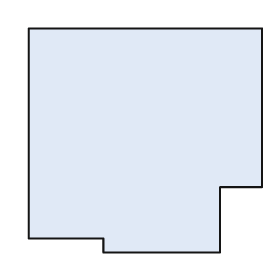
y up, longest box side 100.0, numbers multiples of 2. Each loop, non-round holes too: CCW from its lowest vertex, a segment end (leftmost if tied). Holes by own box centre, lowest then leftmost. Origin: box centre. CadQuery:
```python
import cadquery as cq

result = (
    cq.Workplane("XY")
    .moveTo(-18.0, -48.0)
    .lineTo(32.0, -48.0)
    .lineTo(32.0, -20.0)
    .lineTo(50.0, -20.0)
    .lineTo(50.0, 48.0)
    .lineTo(-50.0, 48.0)
    .lineTo(-50.0, -42.0)
    .lineTo(-18.0, -42.0)
    .close()
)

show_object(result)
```